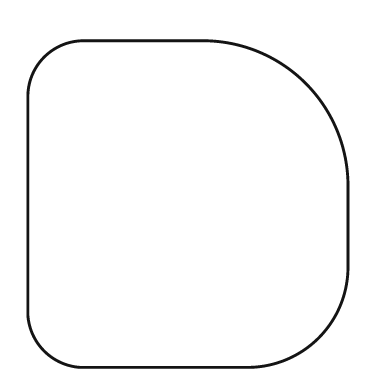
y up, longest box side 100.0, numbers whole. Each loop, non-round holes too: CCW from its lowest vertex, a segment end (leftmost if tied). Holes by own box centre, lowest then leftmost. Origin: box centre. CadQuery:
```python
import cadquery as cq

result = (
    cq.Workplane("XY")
    .moveTo(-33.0, -50.0)
    .lineTo(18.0, -50.0)
    .threePointArc((40.0, -41.0), (49.0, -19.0))
    .lineTo(49.0, 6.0)
    .threePointArc((36.0, 37.0), (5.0, 50.0))
    .lineTo(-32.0, 50.0)
    .threePointArc((-44.0, 45.0), (-49.0, 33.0))
    .lineTo(-49.0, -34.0)
    .threePointArc((-44.0, -45.0), (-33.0, -50.0))
    .close()
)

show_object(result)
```